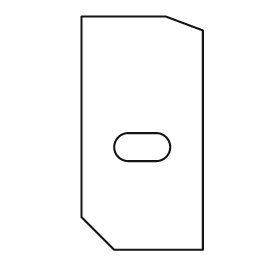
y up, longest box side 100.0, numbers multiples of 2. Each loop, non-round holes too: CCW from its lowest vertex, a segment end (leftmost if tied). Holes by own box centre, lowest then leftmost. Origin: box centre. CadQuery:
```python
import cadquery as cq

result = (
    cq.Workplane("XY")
    .moveTo(-12.0, -50.0)
    .lineTo(26.0, -50.0)
    .lineTo(26.0, 44.0)
    .lineTo(10.0, 50.0)
    .lineTo(-26.0, 50.0)
    .lineTo(-26.0, -36.0)
    .close()
    .moveTo(-6.0, -12.0)
    .lineTo(6.0, -12.0)
    .threePointArc((12.0, -6.0), (6.0, 0.0))
    .lineTo(-6.0, 0.0)
    .threePointArc((-12.0, -6.0), (-6.0, -12.0))
    .close()
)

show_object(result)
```